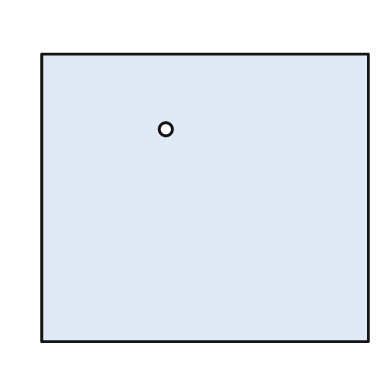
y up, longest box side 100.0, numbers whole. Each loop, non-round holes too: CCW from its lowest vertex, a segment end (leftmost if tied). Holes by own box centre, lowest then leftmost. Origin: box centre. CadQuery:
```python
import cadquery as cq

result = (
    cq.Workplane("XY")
    .moveTo(-50.0, -44.0)
    .lineTo(50.0, -44.0)
    .lineTo(50.0, 44.0)
    .lineTo(-50.0, 44.0)
    .close()
    .moveTo(-12.0, 21.0)
    .circle(2.0)
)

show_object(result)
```